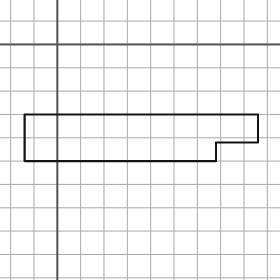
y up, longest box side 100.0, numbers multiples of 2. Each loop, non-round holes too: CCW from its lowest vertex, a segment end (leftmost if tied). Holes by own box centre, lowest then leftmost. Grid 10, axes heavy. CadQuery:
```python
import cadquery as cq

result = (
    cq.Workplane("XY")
    .moveTo(-14.0, -50.0)
    .lineTo(68.0, -50.0)
    .lineTo(68.0, -42.0)
    .lineTo(86.0, -42.0)
    .lineTo(86.0, -30.0)
    .lineTo(-14.0, -30.0)
    .close()
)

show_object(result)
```